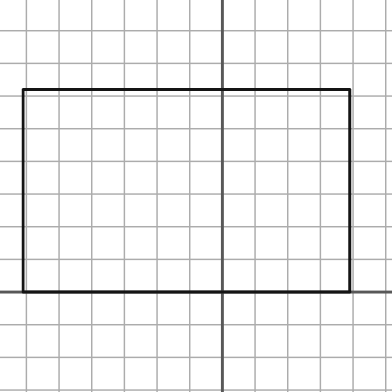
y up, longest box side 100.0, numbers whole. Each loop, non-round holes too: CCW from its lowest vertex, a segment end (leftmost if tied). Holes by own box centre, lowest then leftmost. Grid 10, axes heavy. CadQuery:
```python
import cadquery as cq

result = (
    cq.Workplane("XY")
    .moveTo(-61.0, 0.0)
    .lineTo(39.0, 0.0)
    .lineTo(39.0, 62.0)
    .lineTo(-61.0, 62.0)
    .close()
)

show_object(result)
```